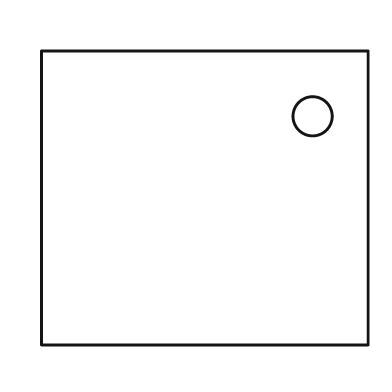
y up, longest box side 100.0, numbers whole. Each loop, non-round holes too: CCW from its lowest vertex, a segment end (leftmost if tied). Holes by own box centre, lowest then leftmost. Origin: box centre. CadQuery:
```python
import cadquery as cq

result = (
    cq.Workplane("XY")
    .moveTo(-50.0, -45.0)
    .lineTo(50.0, -45.0)
    .lineTo(50.0, 45.0)
    .lineTo(-50.0, 45.0)
    .close()
    .moveTo(33.0, 25.0)
    .circle(6.0)
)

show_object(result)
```